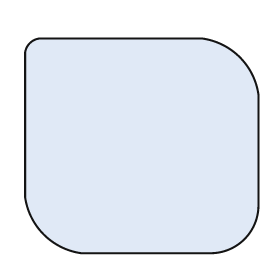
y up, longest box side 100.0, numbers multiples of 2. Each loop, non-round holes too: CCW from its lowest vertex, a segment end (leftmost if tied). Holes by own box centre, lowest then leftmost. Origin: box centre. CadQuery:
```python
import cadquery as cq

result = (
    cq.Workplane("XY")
    .moveTo(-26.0, -46.0)
    .lineTo(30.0, -46.0)
    .threePointArc((44.0, -40.0), (50.0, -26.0))
    .lineTo(50.0, 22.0)
    .threePointArc((42.0, 38.0), (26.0, 46.0))
    .lineTo(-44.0, 46.0)
    .threePointArc((-48.0, 44.0), (-50.0, 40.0))
    .lineTo(-50.0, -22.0)
    .threePointArc((-42.0, -38.0), (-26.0, -46.0))
    .close()
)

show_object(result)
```